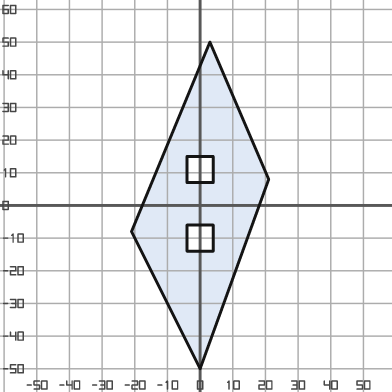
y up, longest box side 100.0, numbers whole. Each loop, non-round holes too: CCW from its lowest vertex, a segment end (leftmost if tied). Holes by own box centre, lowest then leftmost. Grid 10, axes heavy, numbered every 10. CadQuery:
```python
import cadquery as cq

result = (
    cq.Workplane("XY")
    .moveTo(0.0, -50.0)
    .lineTo(21.0, 8.0)
    .lineTo(3.0, 50.0)
    .lineTo(-21.0, -8.0)
    .close()
    .moveTo(-4.0, -14.0)
    .lineTo(4.0, -14.0)
    .lineTo(4.0, -6.0)
    .lineTo(-4.0, -6.0)
    .close()
    .moveTo(-4.0, 7.0)
    .lineTo(4.0, 7.0)
    .lineTo(4.0, 15.0)
    .lineTo(-4.0, 15.0)
    .close()
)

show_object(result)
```